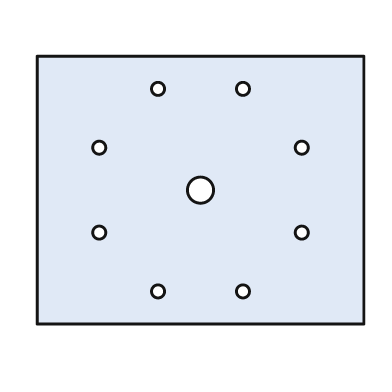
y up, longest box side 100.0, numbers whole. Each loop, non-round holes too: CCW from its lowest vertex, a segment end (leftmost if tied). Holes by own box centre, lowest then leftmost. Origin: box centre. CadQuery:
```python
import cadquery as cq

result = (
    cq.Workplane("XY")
    .moveTo(-50.0, -41.0)
    .lineTo(50.0, -41.0)
    .lineTo(50.0, 41.0)
    .lineTo(-50.0, 41.0)
    .close()
    .moveTo(-13.0, -31.0)
    .circle(2.0)
    .moveTo(13.0, -31.0)
    .circle(2.0)
    .moveTo(-31.0, -13.0)
    .circle(2.0)
    .moveTo(31.0, -13.0)
    .circle(2.0)
    .moveTo(0.0, 0.0)
    .circle(4.0)
    .moveTo(-31.0, 13.0)
    .circle(2.0)
    .moveTo(31.0, 13.0)
    .circle(2.0)
    .moveTo(-13.0, 31.0)
    .circle(2.0)
    .moveTo(13.0, 31.0)
    .circle(2.0)
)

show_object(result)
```